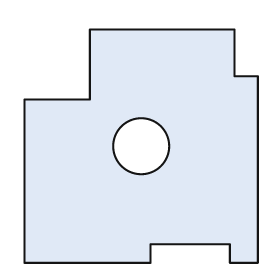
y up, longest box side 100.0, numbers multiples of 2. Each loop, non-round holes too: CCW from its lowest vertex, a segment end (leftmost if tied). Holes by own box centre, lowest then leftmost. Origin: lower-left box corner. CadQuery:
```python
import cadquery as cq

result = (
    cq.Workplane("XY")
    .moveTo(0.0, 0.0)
    .lineTo(54.0, 0.0)
    .lineTo(54.0, 8.0)
    .lineTo(88.0, 8.0)
    .lineTo(88.0, 0.0)
    .lineTo(100.0, 0.0)
    .lineTo(100.0, 80.0)
    .lineTo(90.0, 80.0)
    .lineTo(90.0, 100.0)
    .lineTo(28.0, 100.0)
    .lineTo(28.0, 70.0)
    .lineTo(0.0, 70.0)
    .close()
    .moveTo(50.0, 50.0)
    .circle(12.0)
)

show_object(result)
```